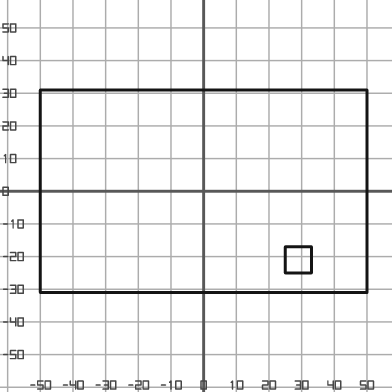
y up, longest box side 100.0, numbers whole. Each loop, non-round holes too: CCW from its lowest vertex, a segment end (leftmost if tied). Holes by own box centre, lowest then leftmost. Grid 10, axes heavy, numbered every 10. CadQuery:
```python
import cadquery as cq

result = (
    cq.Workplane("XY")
    .moveTo(-50.0, -31.0)
    .lineTo(50.0, -31.0)
    .lineTo(50.0, 31.0)
    .lineTo(-50.0, 31.0)
    .close()
    .moveTo(25.0, -25.0)
    .lineTo(33.0, -25.0)
    .lineTo(33.0, -17.0)
    .lineTo(25.0, -17.0)
    .close()
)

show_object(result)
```